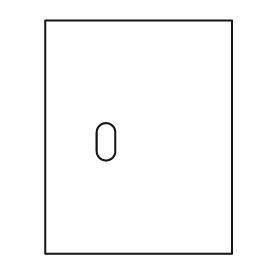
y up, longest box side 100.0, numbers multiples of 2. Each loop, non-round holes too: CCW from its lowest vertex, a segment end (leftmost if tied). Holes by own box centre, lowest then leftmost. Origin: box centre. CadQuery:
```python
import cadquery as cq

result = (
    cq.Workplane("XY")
    .moveTo(-40.0, -50.0)
    .lineTo(40.0, -50.0)
    .lineTo(40.0, 50.0)
    .lineTo(-40.0, 50.0)
    .close()
    .moveTo(-18.0, -6.0)
    .threePointArc((-14.0, -10.0), (-10.0, -6.0))
    .lineTo(-10.0, 2.0)
    .threePointArc((-14.0, 6.0), (-18.0, 2.0))
    .close()
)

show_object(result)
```